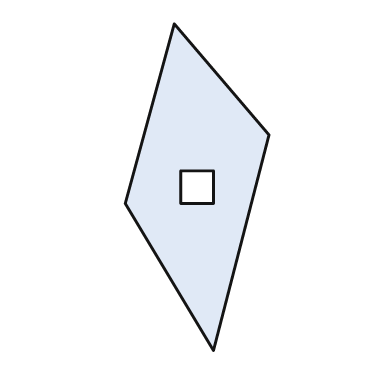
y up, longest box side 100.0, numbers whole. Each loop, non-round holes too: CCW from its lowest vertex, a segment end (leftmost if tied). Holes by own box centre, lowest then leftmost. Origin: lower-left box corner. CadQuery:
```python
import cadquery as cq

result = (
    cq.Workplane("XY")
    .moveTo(27.0, 0.0)
    .lineTo(44.0, 66.0)
    .lineTo(15.0, 100.0)
    .lineTo(0.0, 45.0)
    .close()
    .moveTo(17.0, 45.0)
    .lineTo(27.0, 45.0)
    .lineTo(27.0, 55.0)
    .lineTo(17.0, 55.0)
    .close()
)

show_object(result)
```